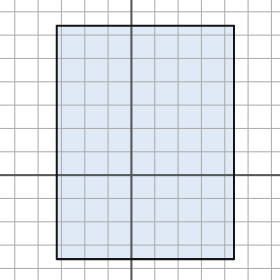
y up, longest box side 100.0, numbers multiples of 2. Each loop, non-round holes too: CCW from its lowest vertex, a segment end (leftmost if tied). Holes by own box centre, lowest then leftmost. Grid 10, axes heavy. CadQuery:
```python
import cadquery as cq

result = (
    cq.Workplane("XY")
    .moveTo(-32.0, -36.0)
    .lineTo(44.0, -36.0)
    .lineTo(44.0, 64.0)
    .lineTo(-32.0, 64.0)
    .close()
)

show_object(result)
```